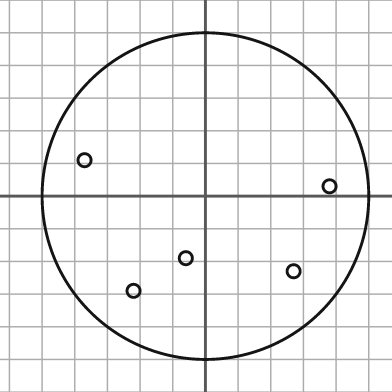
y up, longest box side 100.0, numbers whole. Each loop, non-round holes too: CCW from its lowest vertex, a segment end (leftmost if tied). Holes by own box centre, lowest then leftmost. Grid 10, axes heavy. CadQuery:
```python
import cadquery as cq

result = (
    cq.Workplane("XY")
    .moveTo(0.0, 0.0)
    .circle(50.0)
    .moveTo(-22.0, -29.0)
    .circle(2.0)
    .moveTo(27.0, -23.0)
    .circle(2.0)
    .moveTo(-6.0, -19.0)
    .circle(2.0)
    .moveTo(38.0, 3.0)
    .circle(2.0)
    .moveTo(-37.0, 11.0)
    .circle(2.0)
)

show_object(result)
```